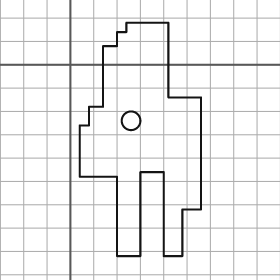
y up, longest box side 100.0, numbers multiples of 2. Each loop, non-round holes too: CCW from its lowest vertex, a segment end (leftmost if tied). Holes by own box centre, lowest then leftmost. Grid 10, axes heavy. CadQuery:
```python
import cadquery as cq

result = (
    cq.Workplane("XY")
    .moveTo(20.0, -82.0)
    .lineTo(30.0, -82.0)
    .lineTo(30.0, -46.0)
    .lineTo(40.0, -46.0)
    .lineTo(40.0, -82.0)
    .lineTo(48.0, -82.0)
    .lineTo(48.0, -62.0)
    .lineTo(56.0, -62.0)
    .lineTo(56.0, -14.0)
    .lineTo(42.0, -14.0)
    .lineTo(42.0, 18.0)
    .lineTo(24.0, 18.0)
    .lineTo(24.0, 14.0)
    .lineTo(20.0, 14.0)
    .lineTo(20.0, 8.0)
    .lineTo(14.0, 8.0)
    .lineTo(14.0, -18.0)
    .lineTo(8.0, -18.0)
    .lineTo(8.0, -26.0)
    .lineTo(4.0, -26.0)
    .lineTo(4.0, -48.0)
    .lineTo(20.0, -48.0)
    .close()
    .moveTo(26.0, -24.0)
    .circle(4.0)
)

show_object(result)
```